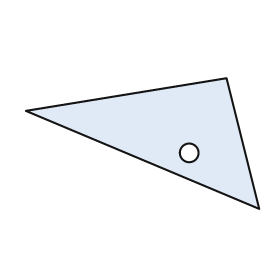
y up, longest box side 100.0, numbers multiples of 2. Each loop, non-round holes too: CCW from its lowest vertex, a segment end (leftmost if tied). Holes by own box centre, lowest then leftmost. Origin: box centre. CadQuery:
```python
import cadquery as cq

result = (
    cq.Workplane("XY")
    .moveTo(50.0, -28.0)
    .lineTo(36.0, 28.0)
    .lineTo(-50.0, 14.0)
    .close()
    .moveTo(20.0, -4.0)
    .circle(4.0)
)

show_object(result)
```